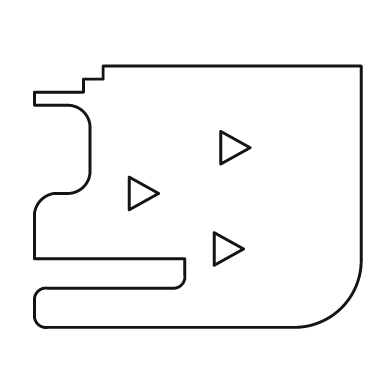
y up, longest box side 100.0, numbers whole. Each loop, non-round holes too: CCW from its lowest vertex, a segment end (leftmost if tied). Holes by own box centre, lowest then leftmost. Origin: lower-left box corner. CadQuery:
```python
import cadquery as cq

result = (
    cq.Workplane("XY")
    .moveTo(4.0, 0.0)
    .lineTo(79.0, 0.0)
    .threePointArc((94.0, 6.0), (100.0, 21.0))
    .lineTo(100.0, 80.0)
    .lineTo(21.0, 80.0)
    .lineTo(21.0, 76.0)
    .lineTo(15.0, 76.0)
    .lineTo(15.0, 72.0)
    .lineTo(0.0, 72.0)
    .lineTo(0.0, 68.0)
    .lineTo(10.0, 68.0)
    .threePointArc((15.0, 66.0), (17.0, 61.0))
    .lineTo(17.0, 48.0)
    .threePointArc((15.0, 43.0), (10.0, 41.0))
    .lineTo(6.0, 41.0)
    .threePointArc((2.0, 39.0), (0.0, 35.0))
    .lineTo(0.0, 21.0)
    .lineTo(46.0, 21.0)
    .lineTo(46.0, 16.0)
    .threePointArc((45.0, 13.0), (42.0, 12.0))
    .lineTo(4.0, 12.0)
    .threePointArc((1.0, 11.0), (0.0, 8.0))
    .lineTo(0.0, 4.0)
    .threePointArc((1.0, 1.0), (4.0, 0.0))
    .close()
    .moveTo(55.0, 19.0)
    .lineTo(64.0, 24.0)
    .lineTo(55.0, 29.0)
    .close()
    .moveTo(29.0, 36.0)
    .lineTo(38.0, 41.0)
    .lineTo(29.0, 46.0)
    .close()
    .moveTo(57.0, 50.0)
    .lineTo(66.0, 55.0)
    .lineTo(57.0, 60.0)
    .close()
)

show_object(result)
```